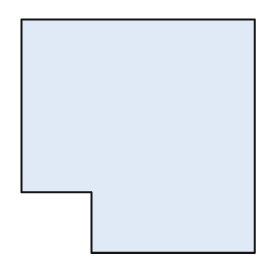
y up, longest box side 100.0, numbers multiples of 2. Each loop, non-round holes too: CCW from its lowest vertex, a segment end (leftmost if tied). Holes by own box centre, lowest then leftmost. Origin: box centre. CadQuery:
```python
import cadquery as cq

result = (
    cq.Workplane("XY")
    .moveTo(-20.0, -50.0)
    .lineTo(50.0, -50.0)
    .lineTo(50.0, 50.0)
    .lineTo(-50.0, 50.0)
    .lineTo(-50.0, -24.0)
    .lineTo(-20.0, -24.0)
    .close()
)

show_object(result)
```